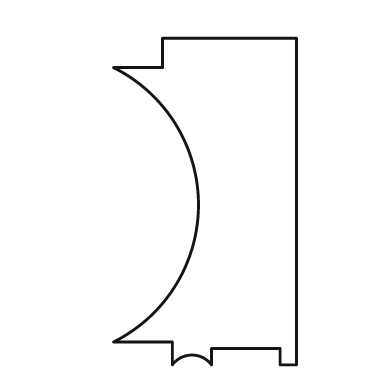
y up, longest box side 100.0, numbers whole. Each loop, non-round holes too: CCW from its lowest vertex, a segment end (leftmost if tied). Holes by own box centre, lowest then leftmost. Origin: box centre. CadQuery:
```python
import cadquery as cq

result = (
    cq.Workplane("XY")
    .moveTo(-10.0, -50.0)
    .threePointArc((-4.0, -47.0), (2.0, -50.0))
    .lineTo(2.0, -45.0)
    .lineTo(23.0, -45.0)
    .lineTo(23.0, -50.0)
    .lineTo(28.0, -50.0)
    .lineTo(28.0, 50.0)
    .lineTo(-13.0, 50.0)
    .lineTo(-13.0, 41.0)
    .lineTo(-28.0, 41.0)
    .threePointArc((-2.0, -1.0), (-28.0, -43.0))
    .lineTo(-10.0, -43.0)
    .close()
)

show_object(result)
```